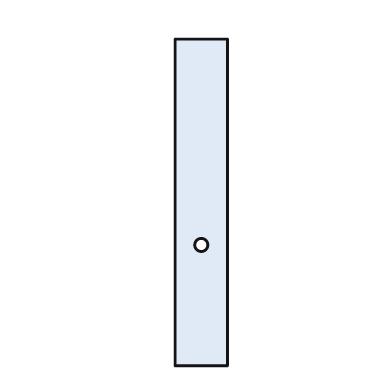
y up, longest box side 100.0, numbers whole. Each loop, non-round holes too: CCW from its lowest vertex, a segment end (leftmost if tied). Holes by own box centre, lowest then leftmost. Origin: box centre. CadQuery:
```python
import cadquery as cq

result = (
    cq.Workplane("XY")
    .moveTo(-8.0, -50.0)
    .lineTo(8.0, -50.0)
    .lineTo(8.0, 50.0)
    .lineTo(-8.0, 50.0)
    .close()
    .moveTo(0.0, -13.0)
    .circle(2.0)
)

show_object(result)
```